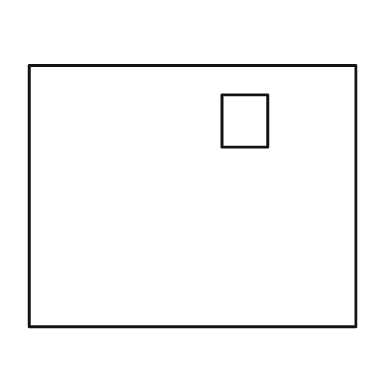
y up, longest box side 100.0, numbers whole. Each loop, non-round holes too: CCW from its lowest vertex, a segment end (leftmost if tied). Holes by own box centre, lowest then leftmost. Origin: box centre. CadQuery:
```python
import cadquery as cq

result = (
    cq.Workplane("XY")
    .moveTo(-50.0, -40.0)
    .lineTo(50.0, -40.0)
    .lineTo(50.0, 40.0)
    .lineTo(-50.0, 40.0)
    .close()
    .moveTo(9.0, 15.0)
    .lineTo(23.0, 15.0)
    .lineTo(23.0, 31.0)
    .lineTo(9.0, 31.0)
    .close()
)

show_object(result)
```